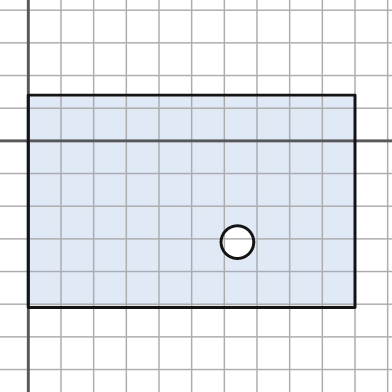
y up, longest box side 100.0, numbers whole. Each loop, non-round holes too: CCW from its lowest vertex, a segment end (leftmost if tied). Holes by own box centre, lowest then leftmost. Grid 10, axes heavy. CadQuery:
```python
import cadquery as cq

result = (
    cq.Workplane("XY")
    .moveTo(0.0, -51.0)
    .lineTo(100.0, -51.0)
    .lineTo(100.0, 14.0)
    .lineTo(0.0, 14.0)
    .close()
    .moveTo(64.0, -31.0)
    .circle(5.0)
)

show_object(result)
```